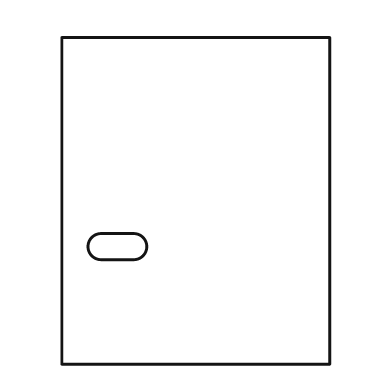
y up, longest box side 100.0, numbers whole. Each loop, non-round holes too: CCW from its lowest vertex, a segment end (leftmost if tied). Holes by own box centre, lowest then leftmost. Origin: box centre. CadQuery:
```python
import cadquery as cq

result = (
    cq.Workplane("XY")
    .moveTo(-41.0, -50.0)
    .lineTo(41.0, -50.0)
    .lineTo(41.0, 50.0)
    .lineTo(-41.0, 50.0)
    .close()
    .moveTo(-29.0, -18.0)
    .lineTo(-19.0, -18.0)
    .threePointArc((-15.0, -14.0), (-19.0, -10.0))
    .lineTo(-29.0, -10.0)
    .threePointArc((-33.0, -14.0), (-29.0, -18.0))
    .close()
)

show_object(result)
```